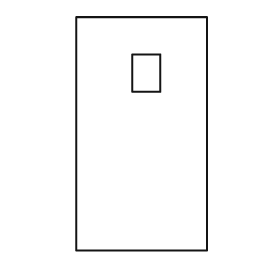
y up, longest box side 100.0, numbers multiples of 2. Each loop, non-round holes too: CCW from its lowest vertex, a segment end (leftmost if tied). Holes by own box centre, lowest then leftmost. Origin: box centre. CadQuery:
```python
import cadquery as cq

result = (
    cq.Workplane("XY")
    .moveTo(-28.0, -50.0)
    .lineTo(28.0, -50.0)
    .lineTo(28.0, 50.0)
    .lineTo(-28.0, 50.0)
    .close()
    .moveTo(-4.0, 18.0)
    .lineTo(8.0, 18.0)
    .lineTo(8.0, 34.0)
    .lineTo(-4.0, 34.0)
    .close()
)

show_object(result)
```